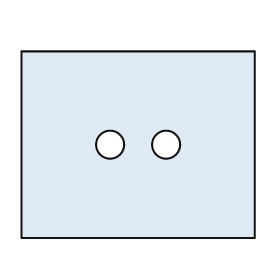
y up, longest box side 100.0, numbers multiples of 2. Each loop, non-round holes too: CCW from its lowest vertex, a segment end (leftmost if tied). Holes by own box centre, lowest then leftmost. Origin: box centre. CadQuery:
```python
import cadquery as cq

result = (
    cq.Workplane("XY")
    .moveTo(-50.0, -40.0)
    .lineTo(50.0, -40.0)
    .lineTo(50.0, 40.0)
    .lineTo(-50.0, 40.0)
    .close()
    .moveTo(-12.0, 0.0)
    .circle(6.0)
    .moveTo(12.0, 0.0)
    .circle(6.0)
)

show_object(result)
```